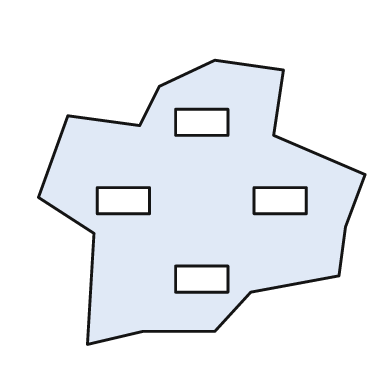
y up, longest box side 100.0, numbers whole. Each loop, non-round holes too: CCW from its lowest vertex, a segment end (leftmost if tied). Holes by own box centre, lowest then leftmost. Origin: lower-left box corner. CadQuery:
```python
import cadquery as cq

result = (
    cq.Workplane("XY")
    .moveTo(15.0, 0.0)
    .lineTo(32.0, 4.0)
    .lineTo(54.0, 4.0)
    .lineTo(65.0, 16.0)
    .lineTo(92.0, 21.0)
    .lineTo(94.0, 36.0)
    .lineTo(100.0, 52.0)
    .lineTo(72.0, 64.0)
    .lineTo(75.0, 84.0)
    .lineTo(54.0, 87.0)
    .lineTo(37.0, 79.0)
    .lineTo(31.0, 67.0)
    .lineTo(9.0, 70.0)
    .lineTo(0.0, 45.0)
    .lineTo(17.0, 34.0)
    .close()
    .moveTo(42.0, 16.0)
    .lineTo(58.0, 16.0)
    .lineTo(58.0, 24.0)
    .lineTo(42.0, 24.0)
    .close()
    .moveTo(18.0, 40.0)
    .lineTo(34.0, 40.0)
    .lineTo(34.0, 48.0)
    .lineTo(18.0, 48.0)
    .close()
    .moveTo(66.0, 40.0)
    .lineTo(82.0, 40.0)
    .lineTo(82.0, 48.0)
    .lineTo(66.0, 48.0)
    .close()
    .moveTo(42.0, 64.0)
    .lineTo(58.0, 64.0)
    .lineTo(58.0, 72.0)
    .lineTo(42.0, 72.0)
    .close()
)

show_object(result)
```